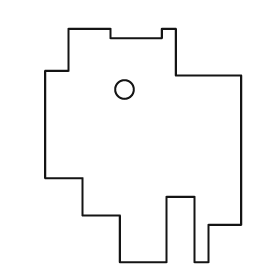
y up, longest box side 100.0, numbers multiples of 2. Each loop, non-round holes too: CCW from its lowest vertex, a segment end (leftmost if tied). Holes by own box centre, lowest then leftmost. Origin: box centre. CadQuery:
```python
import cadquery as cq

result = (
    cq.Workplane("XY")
    .moveTo(-10.0, -50.0)
    .lineTo(10.0, -50.0)
    .lineTo(10.0, -22.0)
    .lineTo(22.0, -22.0)
    .lineTo(22.0, -50.0)
    .lineTo(28.0, -50.0)
    .lineTo(28.0, -34.0)
    .lineTo(42.0, -34.0)
    .lineTo(42.0, 30.0)
    .lineTo(14.0, 30.0)
    .lineTo(14.0, 50.0)
    .lineTo(8.0, 50.0)
    .lineTo(8.0, 46.0)
    .lineTo(-14.0, 46.0)
    .lineTo(-14.0, 50.0)
    .lineTo(-32.0, 50.0)
    .lineTo(-32.0, 32.0)
    .lineTo(-42.0, 32.0)
    .lineTo(-42.0, -14.0)
    .lineTo(-26.0, -14.0)
    .lineTo(-26.0, -30.0)
    .lineTo(-10.0, -30.0)
    .close()
    .moveTo(-8.0, 24.0)
    .circle(4.0)
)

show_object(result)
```